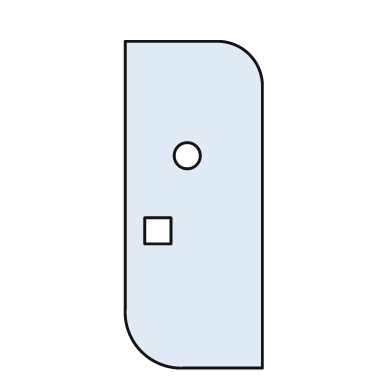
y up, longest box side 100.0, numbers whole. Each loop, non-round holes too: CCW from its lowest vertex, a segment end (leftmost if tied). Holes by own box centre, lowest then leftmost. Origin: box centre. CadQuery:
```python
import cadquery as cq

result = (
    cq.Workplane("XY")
    .moveTo(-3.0, -50.0)
    .lineTo(21.0, -50.0)
    .lineTo(21.0, 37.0)
    .threePointArc((17.0, 46.0), (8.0, 50.0))
    .lineTo(-21.0, 50.0)
    .lineTo(-21.0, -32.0)
    .threePointArc((-16.0, -45.0), (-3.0, -50.0))
    .close()
    .moveTo(-15.0, -12.0)
    .lineTo(-7.0, -12.0)
    .lineTo(-7.0, -4.0)
    .lineTo(-15.0, -4.0)
    .close()
    .moveTo(-2.0, 15.0)
    .circle(4.0)
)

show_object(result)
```